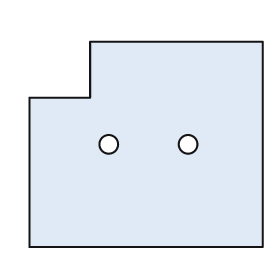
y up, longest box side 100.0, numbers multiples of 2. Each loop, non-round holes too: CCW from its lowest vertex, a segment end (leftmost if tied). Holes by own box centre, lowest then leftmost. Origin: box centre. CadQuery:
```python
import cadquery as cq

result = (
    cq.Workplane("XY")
    .moveTo(-50.0, -44.0)
    .lineTo(50.0, -44.0)
    .lineTo(50.0, 44.0)
    .lineTo(-24.0, 44.0)
    .lineTo(-24.0, 20.0)
    .lineTo(-50.0, 20.0)
    .close()
    .moveTo(-16.0, 0.0)
    .circle(4.0)
    .moveTo(18.0, 0.0)
    .circle(4.0)
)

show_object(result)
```